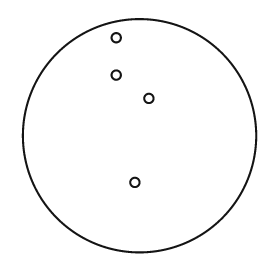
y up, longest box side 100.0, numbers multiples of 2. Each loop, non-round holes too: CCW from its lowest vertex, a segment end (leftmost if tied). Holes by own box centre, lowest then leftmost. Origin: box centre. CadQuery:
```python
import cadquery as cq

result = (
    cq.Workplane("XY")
    .moveTo(0.0, 0.0)
    .circle(50.0)
    .moveTo(-2.0, -20.0)
    .circle(2.0)
    .moveTo(4.0, 16.0)
    .circle(2.0)
    .moveTo(-10.0, 26.0)
    .circle(2.0)
    .moveTo(-10.0, 42.0)
    .circle(2.0)
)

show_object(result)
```